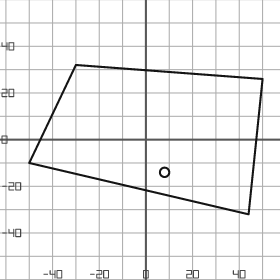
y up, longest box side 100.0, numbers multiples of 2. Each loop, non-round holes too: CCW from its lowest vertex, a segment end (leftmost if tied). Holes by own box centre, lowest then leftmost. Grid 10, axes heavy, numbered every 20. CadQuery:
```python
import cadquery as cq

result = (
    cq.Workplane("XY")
    .moveTo(44.0, -32.0)
    .lineTo(50.0, 26.0)
    .lineTo(-30.0, 32.0)
    .lineTo(-50.0, -10.0)
    .close()
    .moveTo(8.0, -14.0)
    .circle(2.0)
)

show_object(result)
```